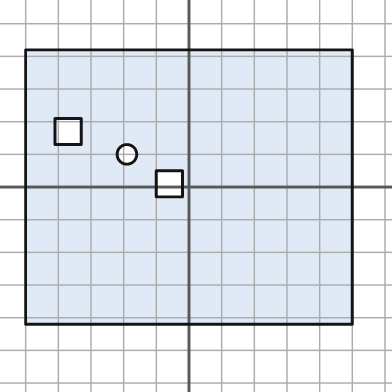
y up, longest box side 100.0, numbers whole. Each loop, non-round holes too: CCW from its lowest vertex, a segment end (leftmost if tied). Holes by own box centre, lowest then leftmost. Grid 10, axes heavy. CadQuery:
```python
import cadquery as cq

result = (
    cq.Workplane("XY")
    .moveTo(-50.0, -42.0)
    .lineTo(50.0, -42.0)
    .lineTo(50.0, 42.0)
    .lineTo(-50.0, 42.0)
    .close()
    .moveTo(-10.0, -3.0)
    .lineTo(-2.0, -3.0)
    .lineTo(-2.0, 5.0)
    .lineTo(-10.0, 5.0)
    .close()
    .moveTo(-19.0, 10.0)
    .circle(3.0)
    .moveTo(-41.0, 13.0)
    .lineTo(-33.0, 13.0)
    .lineTo(-33.0, 21.0)
    .lineTo(-41.0, 21.0)
    .close()
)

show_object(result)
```